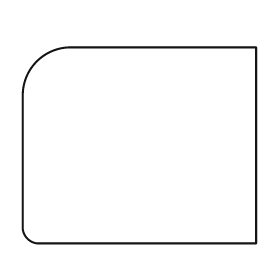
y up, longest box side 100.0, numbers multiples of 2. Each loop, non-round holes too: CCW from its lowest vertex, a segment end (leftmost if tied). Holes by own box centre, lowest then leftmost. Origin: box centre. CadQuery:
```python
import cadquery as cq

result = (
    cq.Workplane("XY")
    .moveTo(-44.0, -42.0)
    .lineTo(50.0, -42.0)
    .lineTo(50.0, 42.0)
    .lineTo(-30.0, 42.0)
    .threePointArc((-44.0, 36.0), (-50.0, 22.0))
    .lineTo(-50.0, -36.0)
    .threePointArc((-48.0, -40.0), (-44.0, -42.0))
    .close()
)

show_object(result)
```